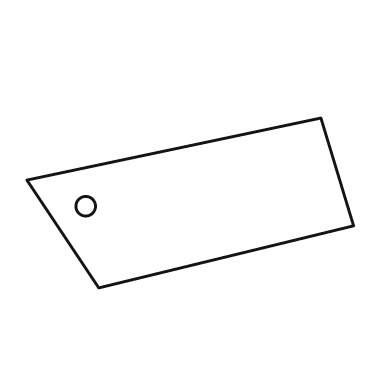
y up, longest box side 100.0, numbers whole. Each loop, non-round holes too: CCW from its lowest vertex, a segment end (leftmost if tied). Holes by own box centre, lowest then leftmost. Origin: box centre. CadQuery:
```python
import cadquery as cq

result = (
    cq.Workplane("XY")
    .moveTo(-28.0, -26.0)
    .lineTo(50.0, -7.0)
    .lineTo(40.0, 26.0)
    .lineTo(-50.0, 7.0)
    .close()
    .moveTo(-32.0, -1.0)
    .circle(3.0)
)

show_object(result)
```